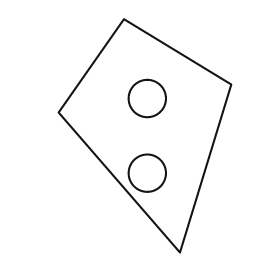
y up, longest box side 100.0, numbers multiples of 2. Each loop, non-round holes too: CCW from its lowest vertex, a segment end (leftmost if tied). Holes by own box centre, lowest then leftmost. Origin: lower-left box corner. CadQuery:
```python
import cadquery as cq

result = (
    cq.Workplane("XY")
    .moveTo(52.0, 0.0)
    .lineTo(74.0, 72.0)
    .lineTo(28.0, 100.0)
    .lineTo(0.0, 60.0)
    .close()
    .moveTo(38.0, 34.0)
    .circle(8.0)
    .moveTo(38.0, 66.0)
    .circle(8.0)
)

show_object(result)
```